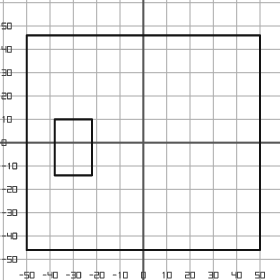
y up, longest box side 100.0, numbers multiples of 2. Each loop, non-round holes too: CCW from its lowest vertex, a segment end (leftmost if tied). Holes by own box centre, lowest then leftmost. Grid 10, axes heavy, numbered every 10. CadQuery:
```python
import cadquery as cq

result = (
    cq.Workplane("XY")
    .moveTo(-50.0, -46.0)
    .lineTo(50.0, -46.0)
    .lineTo(50.0, 46.0)
    .lineTo(-50.0, 46.0)
    .close()
    .moveTo(-38.0, -14.0)
    .lineTo(-22.0, -14.0)
    .lineTo(-22.0, 10.0)
    .lineTo(-38.0, 10.0)
    .close()
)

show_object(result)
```